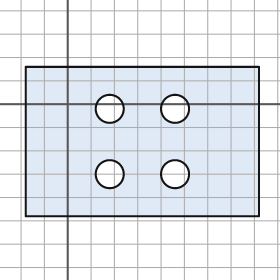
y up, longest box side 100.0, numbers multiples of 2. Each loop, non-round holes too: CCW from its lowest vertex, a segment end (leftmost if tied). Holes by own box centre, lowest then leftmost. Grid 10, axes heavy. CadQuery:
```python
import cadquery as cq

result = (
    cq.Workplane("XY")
    .moveTo(-18.0, -48.0)
    .lineTo(82.0, -48.0)
    .lineTo(82.0, 16.0)
    .lineTo(-18.0, 16.0)
    .close()
    .moveTo(18.0, -30.0)
    .circle(6.0)
    .moveTo(46.0, -30.0)
    .circle(6.0)
    .moveTo(18.0, -2.0)
    .circle(6.0)
    .moveTo(46.0, -2.0)
    .circle(6.0)
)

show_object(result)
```